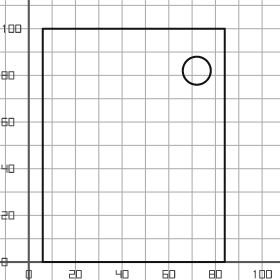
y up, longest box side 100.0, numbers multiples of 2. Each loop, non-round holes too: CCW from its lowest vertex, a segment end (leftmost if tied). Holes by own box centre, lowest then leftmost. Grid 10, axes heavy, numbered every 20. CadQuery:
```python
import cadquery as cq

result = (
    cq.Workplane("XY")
    .moveTo(6.0, 0.0)
    .lineTo(84.0, 0.0)
    .lineTo(84.0, 100.0)
    .lineTo(6.0, 100.0)
    .close()
    .moveTo(72.0, 82.0)
    .circle(6.0)
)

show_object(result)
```